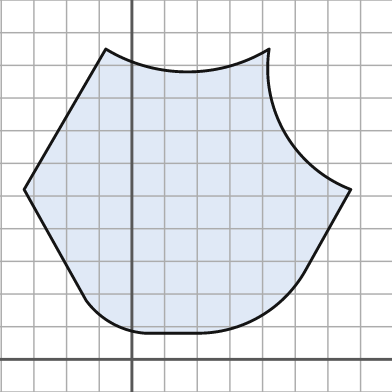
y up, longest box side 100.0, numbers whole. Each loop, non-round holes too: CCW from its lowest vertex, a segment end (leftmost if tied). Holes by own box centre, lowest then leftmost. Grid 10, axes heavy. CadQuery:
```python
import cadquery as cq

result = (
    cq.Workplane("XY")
    .moveTo(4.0, 8.0)
    .lineTo(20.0, 8.0)
    .threePointArc((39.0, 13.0), (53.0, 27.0))
    .lineTo(67.0, 52.0)
    .threePointArc((47.0, 69.0), (42.0, 95.0))
    .threePointArc((17.0, 88.0), (-8.0, 95.0))
    .lineTo(-33.0, 52.0)
    .lineTo(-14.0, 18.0)
    .threePointArc((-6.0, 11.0), (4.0, 8.0))
    .close()
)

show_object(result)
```